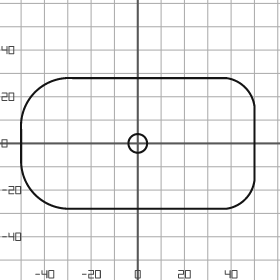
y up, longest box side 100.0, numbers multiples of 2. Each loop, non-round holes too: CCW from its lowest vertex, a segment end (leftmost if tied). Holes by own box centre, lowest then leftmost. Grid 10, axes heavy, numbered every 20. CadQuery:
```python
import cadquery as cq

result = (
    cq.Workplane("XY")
    .moveTo(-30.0, -28.0)
    .lineTo(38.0, -28.0)
    .threePointArc((46.0, -24.0), (50.0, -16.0))
    .lineTo(50.0, 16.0)
    .threePointArc((46.0, 24.0), (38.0, 28.0))
    .lineTo(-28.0, 28.0)
    .threePointArc((-44.0, 22.0), (-50.0, 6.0))
    .lineTo(-50.0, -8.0)
    .threePointArc((-44.0, -22.0), (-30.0, -28.0))
    .close()
    .moveTo(0.0, 0.0)
    .circle(4.0)
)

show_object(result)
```